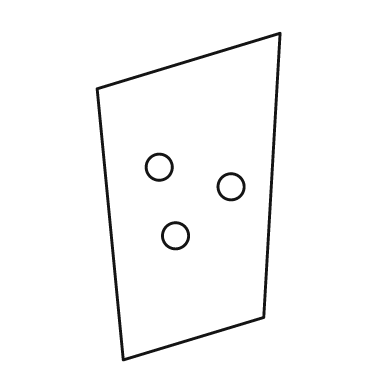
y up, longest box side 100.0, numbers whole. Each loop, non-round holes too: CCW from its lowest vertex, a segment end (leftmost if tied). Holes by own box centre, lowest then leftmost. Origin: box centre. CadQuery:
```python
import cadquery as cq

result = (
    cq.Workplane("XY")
    .moveTo(-20.0, -50.0)
    .lineTo(23.0, -37.0)
    .lineTo(28.0, 50.0)
    .lineTo(-28.0, 33.0)
    .close()
    .moveTo(-4.0, -12.0)
    .circle(4.0)
    .moveTo(13.0, 3.0)
    .circle(4.0)
    .moveTo(-9.0, 9.0)
    .circle(4.0)
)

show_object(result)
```